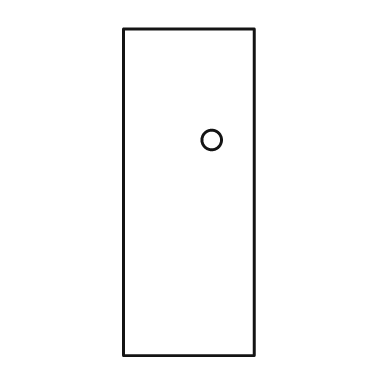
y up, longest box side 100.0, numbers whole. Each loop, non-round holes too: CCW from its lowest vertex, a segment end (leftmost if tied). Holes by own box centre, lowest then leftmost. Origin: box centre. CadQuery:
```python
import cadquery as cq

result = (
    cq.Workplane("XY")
    .moveTo(-20.0, -50.0)
    .lineTo(20.0, -50.0)
    .lineTo(20.0, 50.0)
    .lineTo(-20.0, 50.0)
    .close()
    .moveTo(7.0, 16.0)
    .circle(3.0)
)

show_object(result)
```